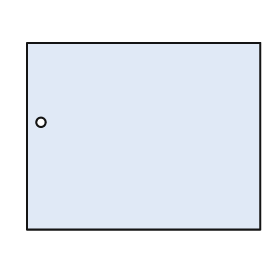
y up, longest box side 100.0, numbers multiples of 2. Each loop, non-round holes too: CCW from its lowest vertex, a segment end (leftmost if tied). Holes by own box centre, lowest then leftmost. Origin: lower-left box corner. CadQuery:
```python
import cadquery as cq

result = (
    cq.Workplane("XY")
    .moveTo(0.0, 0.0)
    .lineTo(100.0, 0.0)
    .lineTo(100.0, 80.0)
    .lineTo(0.0, 80.0)
    .close()
    .moveTo(6.0, 46.0)
    .circle(2.0)
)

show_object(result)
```